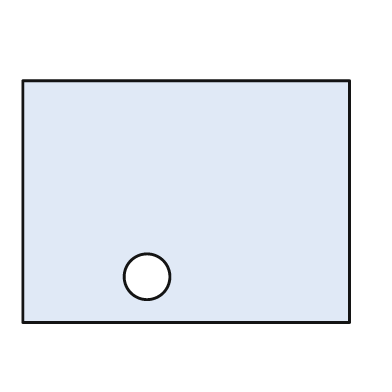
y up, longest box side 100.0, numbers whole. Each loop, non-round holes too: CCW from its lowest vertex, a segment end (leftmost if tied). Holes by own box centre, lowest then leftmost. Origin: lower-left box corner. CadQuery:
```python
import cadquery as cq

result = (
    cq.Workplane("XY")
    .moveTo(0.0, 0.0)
    .lineTo(100.0, 0.0)
    .lineTo(100.0, 74.0)
    .lineTo(0.0, 74.0)
    .close()
    .moveTo(38.0, 14.0)
    .circle(7.0)
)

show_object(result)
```